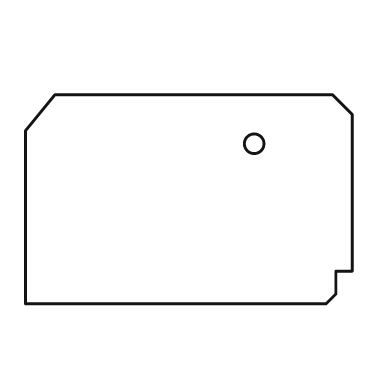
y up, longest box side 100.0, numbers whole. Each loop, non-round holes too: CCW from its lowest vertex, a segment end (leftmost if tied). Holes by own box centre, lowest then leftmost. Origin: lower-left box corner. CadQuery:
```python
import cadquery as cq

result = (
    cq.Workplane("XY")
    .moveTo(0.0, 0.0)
    .lineTo(92.0, 0.0)
    .lineTo(95.0, 3.0)
    .lineTo(95.0, 10.0)
    .lineTo(100.0, 10.0)
    .lineTo(100.0, 58.0)
    .lineTo(94.0, 64.0)
    .lineTo(9.0, 64.0)
    .lineTo(0.0, 53.0)
    .close()
    .moveTo(70.0, 49.0)
    .circle(3.0)
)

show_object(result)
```